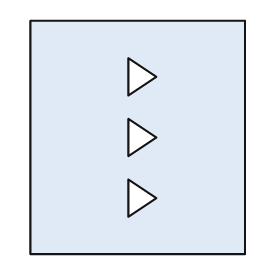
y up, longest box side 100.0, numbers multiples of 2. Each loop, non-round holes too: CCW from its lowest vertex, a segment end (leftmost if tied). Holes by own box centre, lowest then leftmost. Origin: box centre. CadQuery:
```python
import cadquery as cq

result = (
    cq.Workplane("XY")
    .moveTo(-46.0, -50.0)
    .lineTo(46.0, -50.0)
    .lineTo(46.0, 50.0)
    .lineTo(-46.0, 50.0)
    .close()
    .moveTo(-4.0, -34.0)
    .lineTo(8.0, -26.0)
    .lineTo(-4.0, -18.0)
    .close()
    .moveTo(-4.0, -8.0)
    .lineTo(8.0, 0.0)
    .lineTo(-4.0, 8.0)
    .close()
    .moveTo(-4.0, 18.0)
    .lineTo(8.0, 26.0)
    .lineTo(-4.0, 34.0)
    .close()
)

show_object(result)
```